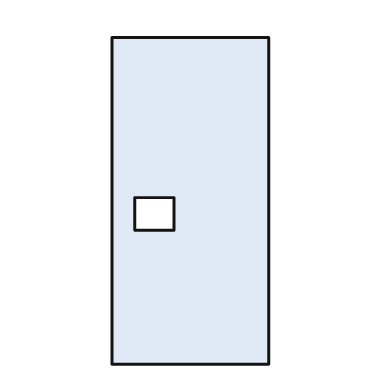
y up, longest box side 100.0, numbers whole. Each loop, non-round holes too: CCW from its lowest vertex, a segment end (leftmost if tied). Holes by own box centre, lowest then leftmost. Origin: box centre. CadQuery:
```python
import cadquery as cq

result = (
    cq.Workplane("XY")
    .moveTo(-24.0, -50.0)
    .lineTo(24.0, -50.0)
    .lineTo(24.0, 50.0)
    .lineTo(-24.0, 50.0)
    .close()
    .moveTo(-17.0, -9.0)
    .lineTo(-5.0, -9.0)
    .lineTo(-5.0, 1.0)
    .lineTo(-17.0, 1.0)
    .close()
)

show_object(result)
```